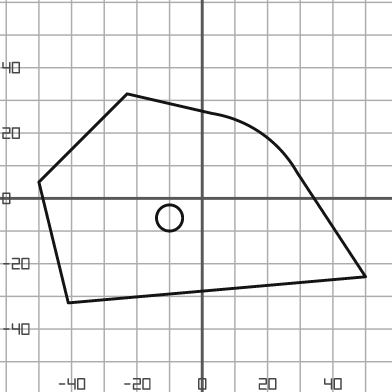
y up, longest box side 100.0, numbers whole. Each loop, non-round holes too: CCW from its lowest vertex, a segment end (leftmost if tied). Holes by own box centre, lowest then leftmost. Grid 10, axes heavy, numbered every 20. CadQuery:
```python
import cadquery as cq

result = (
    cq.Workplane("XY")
    .moveTo(-41.0, -32.0)
    .lineTo(50.0, -24.0)
    .lineTo(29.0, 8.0)
    .threePointArc((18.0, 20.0), (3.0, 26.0))
    .lineTo(-23.0, 32.0)
    .lineTo(-50.0, 5.0)
    .close()
    .moveTo(-10.0, -6.0)
    .circle(4.0)
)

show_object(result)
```